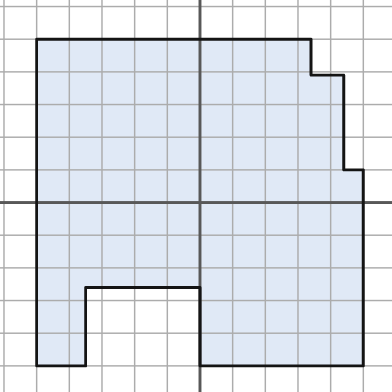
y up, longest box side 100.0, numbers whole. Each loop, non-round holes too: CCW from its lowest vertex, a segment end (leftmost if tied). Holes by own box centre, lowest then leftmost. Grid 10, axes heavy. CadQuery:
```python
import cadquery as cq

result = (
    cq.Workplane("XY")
    .moveTo(-50.0, -50.0)
    .lineTo(-35.0, -50.0)
    .lineTo(-35.0, -26.0)
    .lineTo(0.0, -26.0)
    .lineTo(0.0, -50.0)
    .lineTo(50.0, -50.0)
    .lineTo(50.0, 10.0)
    .lineTo(44.0, 10.0)
    .lineTo(44.0, 39.0)
    .lineTo(34.0, 39.0)
    .lineTo(34.0, 50.0)
    .lineTo(-50.0, 50.0)
    .close()
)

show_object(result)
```